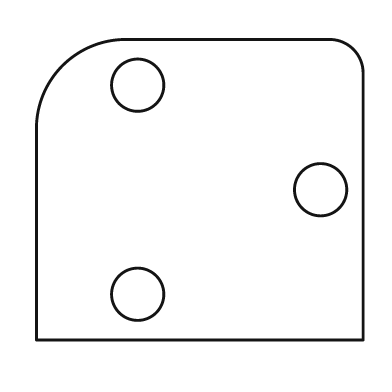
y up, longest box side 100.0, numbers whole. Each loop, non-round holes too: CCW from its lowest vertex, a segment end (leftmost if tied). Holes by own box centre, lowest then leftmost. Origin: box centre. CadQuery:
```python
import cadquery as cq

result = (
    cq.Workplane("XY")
    .moveTo(-50.0, -46.0)
    .lineTo(50.0, -46.0)
    .lineTo(50.0, 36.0)
    .threePointArc((47.0, 43.0), (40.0, 46.0))
    .lineTo(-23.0, 46.0)
    .threePointArc((-42.0, 38.0), (-50.0, 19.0))
    .close()
    .moveTo(-19.0, -32.0)
    .circle(8.0)
    .moveTo(37.0, 0.0)
    .circle(8.0)
    .moveTo(-19.0, 32.0)
    .circle(8.0)
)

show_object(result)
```